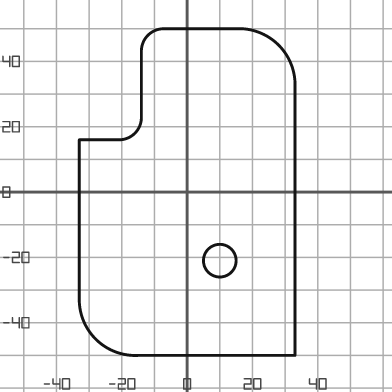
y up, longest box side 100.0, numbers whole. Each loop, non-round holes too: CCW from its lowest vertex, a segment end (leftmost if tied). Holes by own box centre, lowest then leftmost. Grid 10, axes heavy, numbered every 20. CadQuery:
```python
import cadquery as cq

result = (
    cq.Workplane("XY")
    .moveTo(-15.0, -50.0)
    .lineTo(33.0, -50.0)
    .lineTo(33.0, 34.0)
    .threePointArc((28.0, 45.0), (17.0, 50.0))
    .lineTo(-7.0, 50.0)
    .threePointArc((-12.0, 48.0), (-14.0, 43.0))
    .lineTo(-14.0, 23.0)
    .threePointArc((-16.0, 18.0), (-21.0, 16.0))
    .lineTo(-33.0, 16.0)
    .lineTo(-33.0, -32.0)
    .threePointArc((-28.0, -45.0), (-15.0, -50.0))
    .close()
    .moveTo(10.0, -21.0)
    .circle(5.0)
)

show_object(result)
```